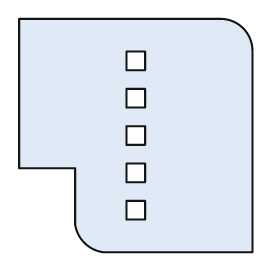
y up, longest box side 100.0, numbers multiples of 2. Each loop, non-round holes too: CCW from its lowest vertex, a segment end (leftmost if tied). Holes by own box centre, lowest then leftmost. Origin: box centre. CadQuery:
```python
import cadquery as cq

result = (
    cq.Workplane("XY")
    .moveTo(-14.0, -50.0)
    .lineTo(50.0, -50.0)
    .lineTo(50.0, 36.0)
    .threePointArc((46.0, 46.0), (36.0, 50.0))
    .lineTo(-50.0, 50.0)
    .lineTo(-50.0, -14.0)
    .lineTo(-26.0, -14.0)
    .lineTo(-26.0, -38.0)
    .threePointArc((-22.0, -46.0), (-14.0, -50.0))
    .close()
    .moveTo(-4.0, -36.0)
    .lineTo(4.0, -36.0)
    .lineTo(4.0, -28.0)
    .lineTo(-4.0, -28.0)
    .close()
    .moveTo(-4.0, -20.0)
    .lineTo(4.0, -20.0)
    .lineTo(4.0, -12.0)
    .lineTo(-4.0, -12.0)
    .close()
    .moveTo(-4.0, -4.0)
    .lineTo(4.0, -4.0)
    .lineTo(4.0, 4.0)
    .lineTo(-4.0, 4.0)
    .close()
    .moveTo(-4.0, 12.0)
    .lineTo(4.0, 12.0)
    .lineTo(4.0, 20.0)
    .lineTo(-4.0, 20.0)
    .close()
    .moveTo(-4.0, 28.0)
    .lineTo(4.0, 28.0)
    .lineTo(4.0, 36.0)
    .lineTo(-4.0, 36.0)
    .close()
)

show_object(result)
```